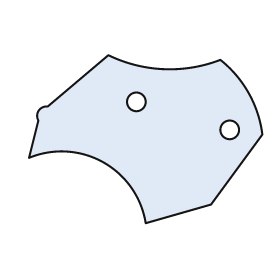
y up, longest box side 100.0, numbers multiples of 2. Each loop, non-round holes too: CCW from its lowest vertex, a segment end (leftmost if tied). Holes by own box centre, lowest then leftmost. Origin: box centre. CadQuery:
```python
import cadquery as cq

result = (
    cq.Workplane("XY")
    .moveTo(0.0, -36.0)
    .lineTo(28.0, -28.0)
    .lineTo(50.0, 2.0)
    .threePointArc((44.0, 20.0), (32.0, 34.0))
    .threePointArc((8.0, 30.0), (-16.0, 36.0))
    .lineTo(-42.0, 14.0)
    .threePointArc((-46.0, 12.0), (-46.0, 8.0))
    .lineTo(-50.0, -8.0)
    .threePointArc((-18.0, -10.0), (0.0, -36.0))
    .close()
    .moveTo(36.0, 4.0)
    .circle(4.0)
    .moveTo(-4.0, 16.0)
    .circle(4.0)
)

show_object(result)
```